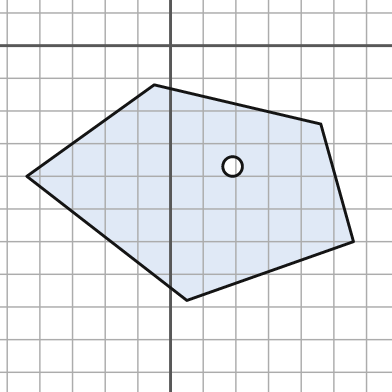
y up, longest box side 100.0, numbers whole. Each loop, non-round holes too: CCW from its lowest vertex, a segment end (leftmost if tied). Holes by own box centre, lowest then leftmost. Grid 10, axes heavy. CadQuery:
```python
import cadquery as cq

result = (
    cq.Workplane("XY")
    .moveTo(5.0, -78.0)
    .lineTo(56.0, -60.0)
    .lineTo(46.0, -24.0)
    .lineTo(-5.0, -12.0)
    .lineTo(-44.0, -40.0)
    .close()
    .moveTo(19.0, -37.0)
    .circle(3.0)
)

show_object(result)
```